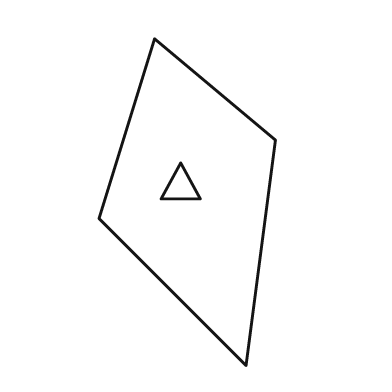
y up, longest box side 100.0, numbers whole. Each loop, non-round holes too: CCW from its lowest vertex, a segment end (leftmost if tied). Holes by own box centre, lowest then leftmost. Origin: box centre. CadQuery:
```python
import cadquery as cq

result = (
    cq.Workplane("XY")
    .moveTo(18.0, -50.0)
    .lineTo(27.0, 19.0)
    .lineTo(-10.0, 50.0)
    .lineTo(-27.0, -5.0)
    .close()
    .moveTo(-8.0, 1.0)
    .lineTo(4.0, 1.0)
    .lineTo(-2.0, 12.0)
    .close()
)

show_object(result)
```